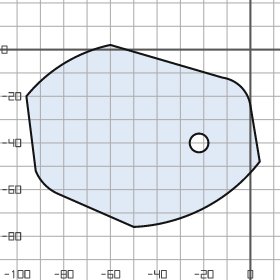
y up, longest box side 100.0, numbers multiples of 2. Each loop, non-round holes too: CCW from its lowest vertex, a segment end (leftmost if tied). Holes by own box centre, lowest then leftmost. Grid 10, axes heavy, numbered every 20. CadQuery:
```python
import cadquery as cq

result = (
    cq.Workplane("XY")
    .moveTo(-50.0, -76.0)
    .threePointArc((-20.0, -68.0), (4.0, -48.0))
    .lineTo(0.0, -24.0)
    .threePointArc((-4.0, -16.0), (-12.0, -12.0))
    .lineTo(-60.0, 2.0)
    .threePointArc((-80.0, -6.0), (-96.0, -20.0))
    .lineTo(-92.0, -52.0)
    .threePointArc((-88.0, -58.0), (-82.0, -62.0))
    .close()
    .moveTo(-22.0, -40.0)
    .circle(4.0)
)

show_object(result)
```